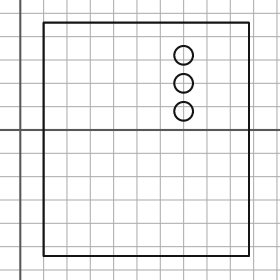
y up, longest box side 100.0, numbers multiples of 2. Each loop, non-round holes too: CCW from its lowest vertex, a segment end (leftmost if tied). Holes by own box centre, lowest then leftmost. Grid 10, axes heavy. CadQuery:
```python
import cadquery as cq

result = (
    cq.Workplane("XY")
    .moveTo(10.0, -54.0)
    .lineTo(98.0, -54.0)
    .lineTo(98.0, 46.0)
    .lineTo(10.0, 46.0)
    .close()
    .moveTo(70.0, 8.0)
    .circle(4.0)
    .moveTo(70.0, 20.0)
    .circle(4.0)
    .moveTo(70.0, 32.0)
    .circle(4.0)
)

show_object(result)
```